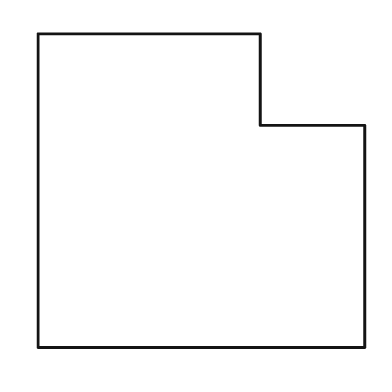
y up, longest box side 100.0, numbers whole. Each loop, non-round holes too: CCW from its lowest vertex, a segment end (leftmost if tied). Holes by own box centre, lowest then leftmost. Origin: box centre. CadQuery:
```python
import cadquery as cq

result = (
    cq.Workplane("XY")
    .moveTo(-50.0, -48.0)
    .lineTo(50.0, -48.0)
    .lineTo(50.0, 20.0)
    .lineTo(18.0, 20.0)
    .lineTo(18.0, 48.0)
    .lineTo(-50.0, 48.0)
    .close()
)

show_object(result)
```